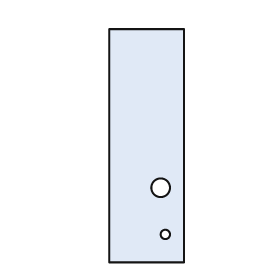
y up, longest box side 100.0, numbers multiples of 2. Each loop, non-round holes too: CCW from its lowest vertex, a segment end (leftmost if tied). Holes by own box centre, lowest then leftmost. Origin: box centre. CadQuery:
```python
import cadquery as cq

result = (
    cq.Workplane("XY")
    .moveTo(-16.0, -50.0)
    .lineTo(16.0, -50.0)
    .lineTo(16.0, 50.0)
    .lineTo(-16.0, 50.0)
    .close()
    .moveTo(8.0, -38.0)
    .circle(2.0)
    .moveTo(6.0, -18.0)
    .circle(4.0)
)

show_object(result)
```